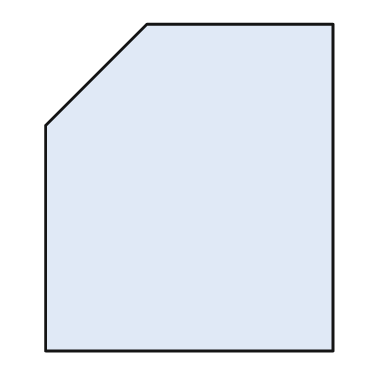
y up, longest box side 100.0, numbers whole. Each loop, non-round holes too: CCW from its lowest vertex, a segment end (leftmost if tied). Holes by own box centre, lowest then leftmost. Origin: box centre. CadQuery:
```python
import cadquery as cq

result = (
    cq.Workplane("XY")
    .moveTo(-44.0, -50.0)
    .lineTo(44.0, -50.0)
    .lineTo(44.0, 50.0)
    .lineTo(-13.0, 50.0)
    .lineTo(-44.0, 19.0)
    .close()
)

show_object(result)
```